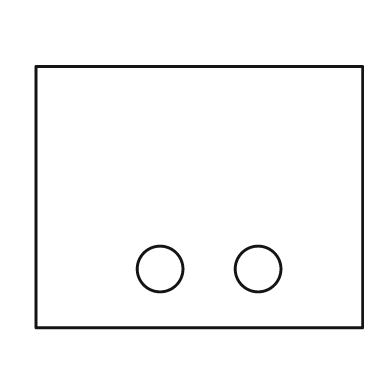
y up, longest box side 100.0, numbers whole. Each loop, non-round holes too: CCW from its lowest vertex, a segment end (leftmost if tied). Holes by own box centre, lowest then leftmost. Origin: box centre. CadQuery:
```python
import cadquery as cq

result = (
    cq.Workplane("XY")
    .moveTo(-50.0, -40.0)
    .lineTo(50.0, -40.0)
    .lineTo(50.0, 40.0)
    .lineTo(-50.0, 40.0)
    .close()
    .moveTo(-12.0, -22.0)
    .circle(7.0)
    .moveTo(18.0, -22.0)
    .circle(7.0)
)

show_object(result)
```